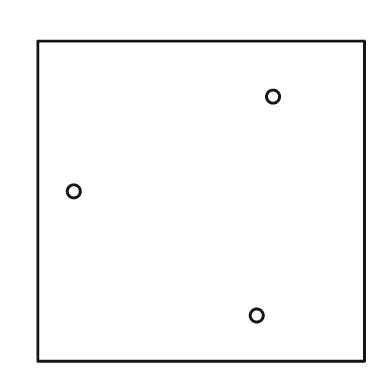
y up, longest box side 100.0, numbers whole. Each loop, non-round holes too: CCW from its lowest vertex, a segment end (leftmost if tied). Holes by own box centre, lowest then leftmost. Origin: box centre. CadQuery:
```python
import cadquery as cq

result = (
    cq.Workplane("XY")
    .moveTo(-50.0, -49.0)
    .lineTo(50.0, -49.0)
    .lineTo(50.0, 49.0)
    .lineTo(-50.0, 49.0)
    .close()
    .moveTo(17.0, -35.0)
    .circle(2.0)
    .moveTo(-39.0, 3.0)
    .circle(2.0)
    .moveTo(22.0, 32.0)
    .circle(2.0)
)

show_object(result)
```